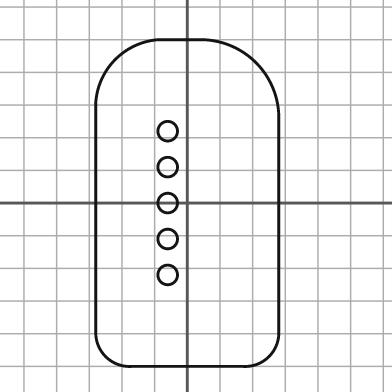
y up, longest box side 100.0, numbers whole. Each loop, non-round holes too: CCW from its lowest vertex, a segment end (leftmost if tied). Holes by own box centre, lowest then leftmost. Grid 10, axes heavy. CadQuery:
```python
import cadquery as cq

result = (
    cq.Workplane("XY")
    .moveTo(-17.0, -50.0)
    .lineTo(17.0, -50.0)
    .threePointArc((25.0, -47.0), (28.0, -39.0))
    .lineTo(28.0, 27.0)
    .threePointArc((21.0, 43.0), (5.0, 50.0))
    .lineTo(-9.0, 50.0)
    .threePointArc((-22.0, 44.0), (-28.0, 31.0))
    .lineTo(-28.0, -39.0)
    .threePointArc((-25.0, -47.0), (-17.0, -50.0))
    .close()
    .moveTo(-6.0, -22.0)
    .circle(3.0)
    .moveTo(-6.0, -11.0)
    .circle(3.0)
    .moveTo(-6.0, 0.0)
    .circle(3.0)
    .moveTo(-6.0, 11.0)
    .circle(3.0)
    .moveTo(-6.0, 22.0)
    .circle(3.0)
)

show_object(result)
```